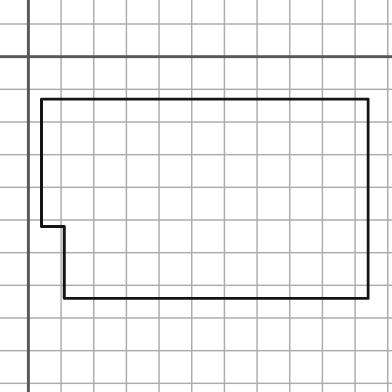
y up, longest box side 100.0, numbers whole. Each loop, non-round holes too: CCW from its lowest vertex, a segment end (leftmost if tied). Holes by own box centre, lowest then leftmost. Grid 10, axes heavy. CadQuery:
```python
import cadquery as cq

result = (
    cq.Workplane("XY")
    .moveTo(11.0, -74.0)
    .lineTo(104.0, -74.0)
    .lineTo(104.0, -13.0)
    .lineTo(4.0, -13.0)
    .lineTo(4.0, -52.0)
    .lineTo(11.0, -52.0)
    .close()
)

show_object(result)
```